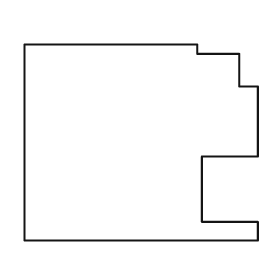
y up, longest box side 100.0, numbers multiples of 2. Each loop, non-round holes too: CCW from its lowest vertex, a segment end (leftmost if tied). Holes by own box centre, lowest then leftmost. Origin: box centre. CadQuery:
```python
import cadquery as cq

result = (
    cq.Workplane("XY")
    .moveTo(-50.0, -42.0)
    .lineTo(50.0, -42.0)
    .lineTo(50.0, -34.0)
    .lineTo(26.0, -34.0)
    .lineTo(26.0, -6.0)
    .lineTo(50.0, -6.0)
    .lineTo(50.0, 24.0)
    .lineTo(42.0, 24.0)
    .lineTo(42.0, 38.0)
    .lineTo(24.0, 38.0)
    .lineTo(24.0, 42.0)
    .lineTo(-50.0, 42.0)
    .close()
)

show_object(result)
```